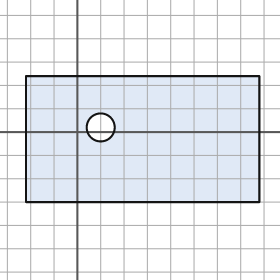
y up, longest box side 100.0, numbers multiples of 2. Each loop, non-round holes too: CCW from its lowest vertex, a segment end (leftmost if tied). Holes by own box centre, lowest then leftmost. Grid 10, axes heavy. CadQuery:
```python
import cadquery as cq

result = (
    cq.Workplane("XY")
    .moveTo(-22.0, -30.0)
    .lineTo(78.0, -30.0)
    .lineTo(78.0, 24.0)
    .lineTo(-22.0, 24.0)
    .close()
    .moveTo(10.0, 2.0)
    .circle(6.0)
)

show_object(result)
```